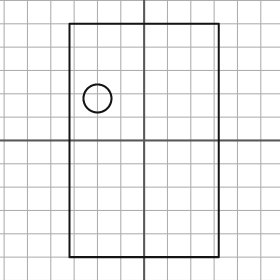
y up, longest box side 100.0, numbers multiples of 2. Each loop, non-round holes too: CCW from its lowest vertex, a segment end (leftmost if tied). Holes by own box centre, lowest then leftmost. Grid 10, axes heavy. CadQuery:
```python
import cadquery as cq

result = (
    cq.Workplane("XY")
    .moveTo(-32.0, -50.0)
    .lineTo(32.0, -50.0)
    .lineTo(32.0, 50.0)
    .lineTo(-32.0, 50.0)
    .close()
    .moveTo(-20.0, 18.0)
    .circle(6.0)
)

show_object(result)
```